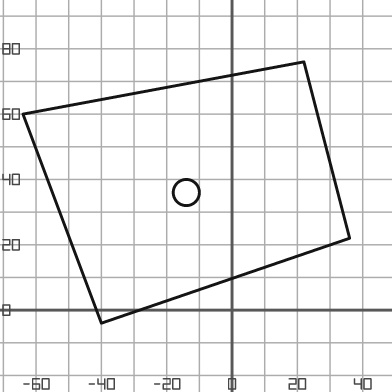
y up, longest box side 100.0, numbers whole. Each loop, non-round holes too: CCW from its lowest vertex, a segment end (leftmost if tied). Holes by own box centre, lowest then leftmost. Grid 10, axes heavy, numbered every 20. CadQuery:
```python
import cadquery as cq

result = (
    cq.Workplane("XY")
    .moveTo(-40.0, -4.0)
    .lineTo(36.0, 22.0)
    .lineTo(22.0, 76.0)
    .lineTo(-64.0, 60.0)
    .close()
    .moveTo(-14.0, 36.0)
    .circle(4.0)
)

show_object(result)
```